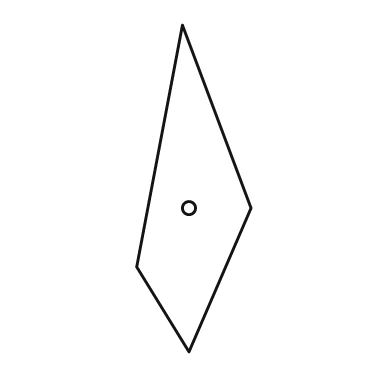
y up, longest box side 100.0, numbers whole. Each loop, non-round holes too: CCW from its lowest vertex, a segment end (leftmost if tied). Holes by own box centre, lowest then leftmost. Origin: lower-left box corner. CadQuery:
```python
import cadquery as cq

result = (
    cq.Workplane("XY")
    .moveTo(16.0, 0.0)
    .lineTo(35.0, 44.0)
    .lineTo(14.0, 100.0)
    .lineTo(0.0, 26.0)
    .close()
    .moveTo(16.0, 44.0)
    .circle(2.0)
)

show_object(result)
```